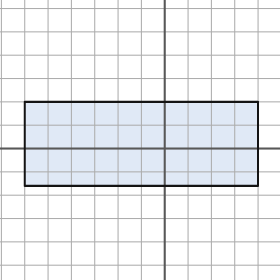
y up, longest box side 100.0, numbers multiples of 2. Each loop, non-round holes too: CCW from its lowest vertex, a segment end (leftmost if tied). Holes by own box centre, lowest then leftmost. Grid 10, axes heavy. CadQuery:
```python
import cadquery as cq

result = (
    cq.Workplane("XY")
    .moveTo(-60.0, -16.0)
    .lineTo(40.0, -16.0)
    .lineTo(40.0, 20.0)
    .lineTo(-60.0, 20.0)
    .close()
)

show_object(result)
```